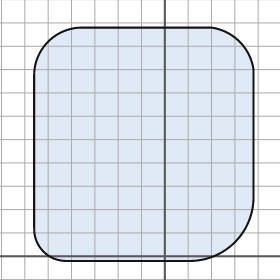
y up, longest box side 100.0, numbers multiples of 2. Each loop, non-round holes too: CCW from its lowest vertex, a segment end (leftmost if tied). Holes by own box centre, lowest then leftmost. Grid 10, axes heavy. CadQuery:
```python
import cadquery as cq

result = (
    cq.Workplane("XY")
    .moveTo(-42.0, -2.0)
    .lineTo(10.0, -2.0)
    .threePointArc((30.0, 6.0), (38.0, 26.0))
    .lineTo(38.0, 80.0)
    .threePointArc((32.0, 92.0), (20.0, 98.0))
    .lineTo(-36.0, 98.0)
    .threePointArc((-50.0, 92.0), (-56.0, 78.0))
    .lineTo(-56.0, 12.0)
    .threePointArc((-52.0, 2.0), (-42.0, -2.0))
    .close()
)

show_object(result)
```